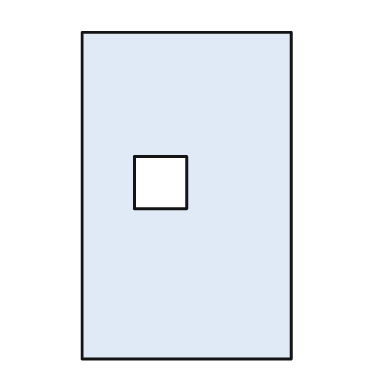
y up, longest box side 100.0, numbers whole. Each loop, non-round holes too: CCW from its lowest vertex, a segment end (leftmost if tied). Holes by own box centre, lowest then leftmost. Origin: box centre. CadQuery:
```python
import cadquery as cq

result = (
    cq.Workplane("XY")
    .moveTo(-32.0, -50.0)
    .lineTo(32.0, -50.0)
    .lineTo(32.0, 50.0)
    .lineTo(-32.0, 50.0)
    .close()
    .moveTo(-16.0, -4.0)
    .lineTo(0.0, -4.0)
    .lineTo(0.0, 12.0)
    .lineTo(-16.0, 12.0)
    .close()
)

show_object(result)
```